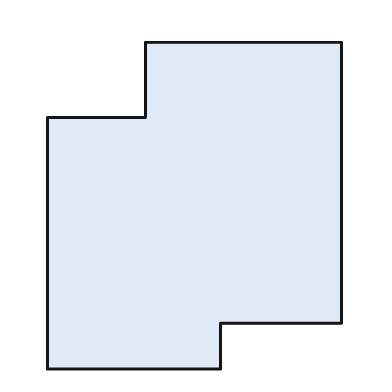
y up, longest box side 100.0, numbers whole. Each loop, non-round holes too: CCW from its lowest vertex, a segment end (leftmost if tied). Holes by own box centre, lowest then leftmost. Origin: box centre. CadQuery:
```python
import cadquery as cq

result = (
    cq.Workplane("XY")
    .moveTo(-45.0, -50.0)
    .lineTo(8.0, -50.0)
    .lineTo(8.0, -36.0)
    .lineTo(45.0, -36.0)
    .lineTo(45.0, 50.0)
    .lineTo(-15.0, 50.0)
    .lineTo(-15.0, 27.0)
    .lineTo(-45.0, 27.0)
    .close()
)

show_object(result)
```